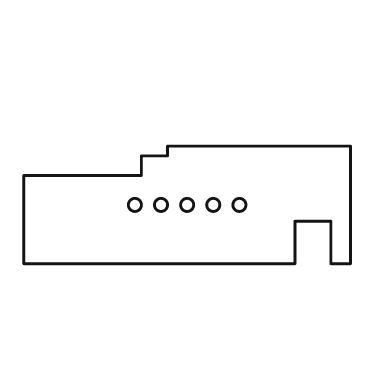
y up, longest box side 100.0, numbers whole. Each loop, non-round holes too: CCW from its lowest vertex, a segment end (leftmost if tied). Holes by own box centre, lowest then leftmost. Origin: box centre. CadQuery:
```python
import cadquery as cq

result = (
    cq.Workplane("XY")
    .moveTo(-50.0, -18.0)
    .lineTo(33.0, -18.0)
    .lineTo(33.0, -5.0)
    .lineTo(44.0, -5.0)
    .lineTo(44.0, -18.0)
    .lineTo(50.0, -18.0)
    .lineTo(50.0, 18.0)
    .lineTo(-6.0, 18.0)
    .lineTo(-6.0, 15.0)
    .lineTo(-14.0, 15.0)
    .lineTo(-14.0, 9.0)
    .lineTo(-50.0, 9.0)
    .close()
    .moveTo(-16.0, 0.0)
    .circle(2.0)
    .moveTo(-8.0, 0.0)
    .circle(2.0)
    .moveTo(0.0, 0.0)
    .circle(2.0)
    .moveTo(8.0, 0.0)
    .circle(2.0)
    .moveTo(16.0, 0.0)
    .circle(2.0)
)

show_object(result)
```